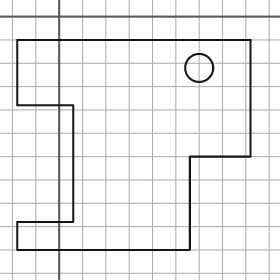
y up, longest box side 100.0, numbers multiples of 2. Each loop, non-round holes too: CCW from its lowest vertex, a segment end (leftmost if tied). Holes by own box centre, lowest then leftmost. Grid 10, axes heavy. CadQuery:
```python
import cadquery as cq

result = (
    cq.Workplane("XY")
    .moveTo(-18.0, -100.0)
    .lineTo(56.0, -100.0)
    .lineTo(56.0, -60.0)
    .lineTo(82.0, -60.0)
    .lineTo(82.0, -10.0)
    .lineTo(-18.0, -10.0)
    .lineTo(-18.0, -38.0)
    .lineTo(6.0, -38.0)
    .lineTo(6.0, -88.0)
    .lineTo(-18.0, -88.0)
    .close()
    .moveTo(60.0, -22.0)
    .circle(6.0)
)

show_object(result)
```